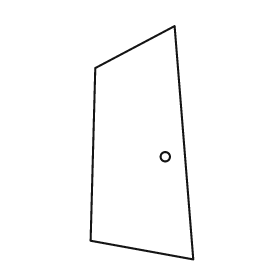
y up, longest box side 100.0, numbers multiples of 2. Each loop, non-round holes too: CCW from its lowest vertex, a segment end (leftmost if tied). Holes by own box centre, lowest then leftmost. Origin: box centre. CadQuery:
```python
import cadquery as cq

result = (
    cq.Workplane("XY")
    .moveTo(22.0, -50.0)
    .lineTo(14.0, 50.0)
    .lineTo(-20.0, 32.0)
    .lineTo(-22.0, -42.0)
    .close()
    .moveTo(10.0, -6.0)
    .circle(2.0)
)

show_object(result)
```